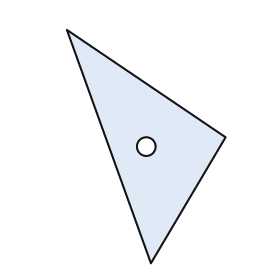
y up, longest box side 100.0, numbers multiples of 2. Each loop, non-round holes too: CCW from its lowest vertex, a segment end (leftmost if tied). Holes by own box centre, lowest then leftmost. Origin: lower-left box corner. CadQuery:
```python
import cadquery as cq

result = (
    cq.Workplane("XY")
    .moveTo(36.0, 0.0)
    .lineTo(68.0, 54.0)
    .lineTo(0.0, 100.0)
    .close()
    .moveTo(34.0, 50.0)
    .circle(4.0)
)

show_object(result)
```